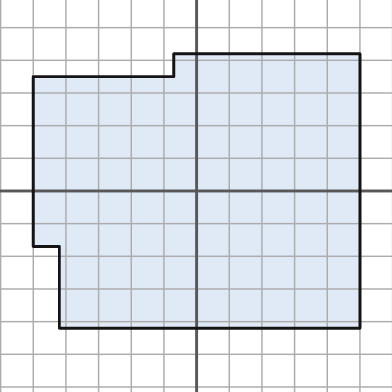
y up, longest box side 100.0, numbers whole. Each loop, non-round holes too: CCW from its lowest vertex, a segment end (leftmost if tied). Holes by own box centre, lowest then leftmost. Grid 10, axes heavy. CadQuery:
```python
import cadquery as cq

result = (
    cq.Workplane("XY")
    .moveTo(-42.0, -42.0)
    .lineTo(50.0, -42.0)
    .lineTo(50.0, 42.0)
    .lineTo(-7.0, 42.0)
    .lineTo(-7.0, 35.0)
    .lineTo(-50.0, 35.0)
    .lineTo(-50.0, -17.0)
    .lineTo(-42.0, -17.0)
    .close()
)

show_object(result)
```